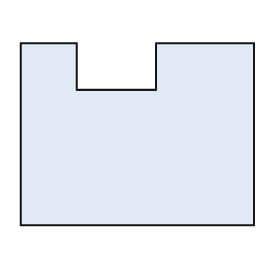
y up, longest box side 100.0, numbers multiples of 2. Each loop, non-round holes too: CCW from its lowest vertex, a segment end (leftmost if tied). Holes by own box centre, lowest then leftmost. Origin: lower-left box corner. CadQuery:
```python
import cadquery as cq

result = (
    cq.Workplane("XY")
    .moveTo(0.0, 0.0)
    .lineTo(100.0, 0.0)
    .lineTo(100.0, 78.0)
    .lineTo(58.0, 78.0)
    .lineTo(58.0, 58.0)
    .lineTo(24.0, 58.0)
    .lineTo(24.0, 78.0)
    .lineTo(0.0, 78.0)
    .close()
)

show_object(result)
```